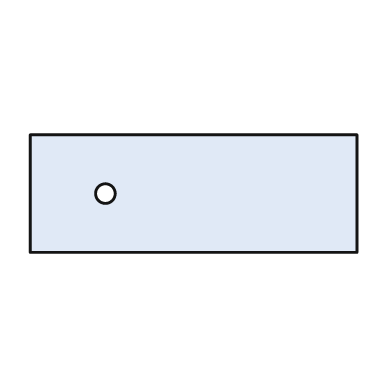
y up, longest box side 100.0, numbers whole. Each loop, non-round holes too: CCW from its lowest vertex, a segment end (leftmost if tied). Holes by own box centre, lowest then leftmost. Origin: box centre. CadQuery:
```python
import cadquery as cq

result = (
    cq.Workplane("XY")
    .moveTo(-50.0, -18.0)
    .lineTo(50.0, -18.0)
    .lineTo(50.0, 18.0)
    .lineTo(-50.0, 18.0)
    .close()
    .moveTo(-27.0, 0.0)
    .circle(3.0)
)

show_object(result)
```